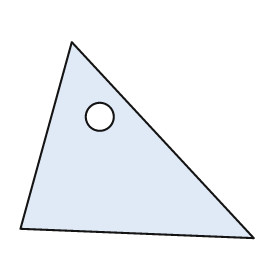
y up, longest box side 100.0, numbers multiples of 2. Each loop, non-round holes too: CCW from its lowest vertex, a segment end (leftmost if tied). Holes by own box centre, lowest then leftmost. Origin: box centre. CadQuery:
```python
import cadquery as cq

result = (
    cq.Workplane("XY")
    .moveTo(50.0, -42.0)
    .lineTo(-28.0, 42.0)
    .lineTo(-50.0, -38.0)
    .close()
    .moveTo(-16.0, 10.0)
    .circle(6.0)
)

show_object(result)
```